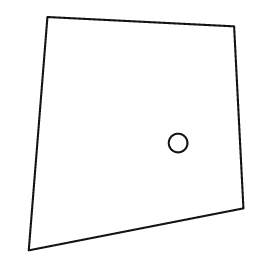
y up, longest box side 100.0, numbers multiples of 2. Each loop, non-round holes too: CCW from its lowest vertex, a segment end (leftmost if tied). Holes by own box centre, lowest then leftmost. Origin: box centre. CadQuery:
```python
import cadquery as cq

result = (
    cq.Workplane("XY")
    .moveTo(-46.0, -50.0)
    .lineTo(46.0, -32.0)
    .lineTo(42.0, 46.0)
    .lineTo(-38.0, 50.0)
    .close()
    .moveTo(18.0, -4.0)
    .circle(4.0)
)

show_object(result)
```